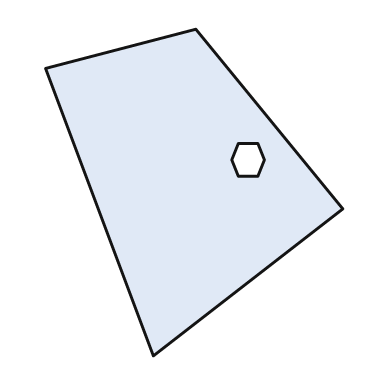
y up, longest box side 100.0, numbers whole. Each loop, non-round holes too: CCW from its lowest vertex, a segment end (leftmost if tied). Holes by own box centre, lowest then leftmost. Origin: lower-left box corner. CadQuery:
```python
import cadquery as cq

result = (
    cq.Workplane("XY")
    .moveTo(33.0, 0.0)
    .lineTo(91.0, 45.0)
    .lineTo(46.0, 100.0)
    .lineTo(0.0, 88.0)
    .close()
    .moveTo(59.0, 55.0)
    .lineTo(65.0, 55.0)
    .lineTo(67.0, 60.0)
    .lineTo(65.0, 65.0)
    .lineTo(59.0, 65.0)
    .lineTo(57.0, 60.0)
    .close()
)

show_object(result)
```